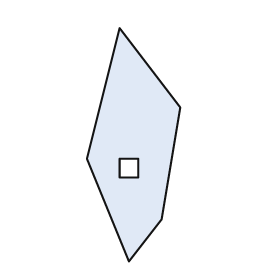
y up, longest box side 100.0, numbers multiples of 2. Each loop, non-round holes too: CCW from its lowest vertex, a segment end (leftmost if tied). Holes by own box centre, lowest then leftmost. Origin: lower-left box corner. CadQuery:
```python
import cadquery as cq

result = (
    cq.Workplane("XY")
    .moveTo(18.0, 0.0)
    .lineTo(32.0, 18.0)
    .lineTo(40.0, 66.0)
    .lineTo(14.0, 100.0)
    .lineTo(0.0, 44.0)
    .close()
    .moveTo(14.0, 36.0)
    .lineTo(22.0, 36.0)
    .lineTo(22.0, 44.0)
    .lineTo(14.0, 44.0)
    .close()
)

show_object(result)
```